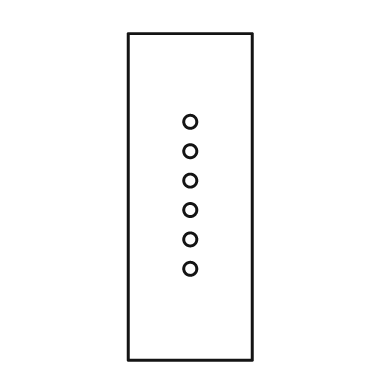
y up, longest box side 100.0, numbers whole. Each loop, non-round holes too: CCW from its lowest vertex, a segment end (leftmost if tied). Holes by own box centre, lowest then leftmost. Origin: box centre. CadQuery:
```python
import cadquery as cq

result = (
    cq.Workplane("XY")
    .moveTo(-19.0, -50.0)
    .lineTo(19.0, -50.0)
    .lineTo(19.0, 50.0)
    .lineTo(-19.0, 50.0)
    .close()
    .moveTo(0.0, -22.0)
    .circle(2.0)
    .moveTo(0.0, -13.0)
    .circle(2.0)
    .moveTo(0.0, -4.0)
    .circle(2.0)
    .moveTo(0.0, 5.0)
    .circle(2.0)
    .moveTo(0.0, 14.0)
    .circle(2.0)
    .moveTo(0.0, 23.0)
    .circle(2.0)
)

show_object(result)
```